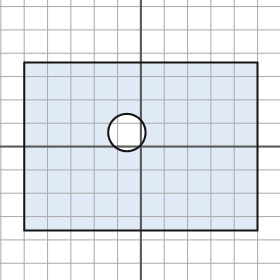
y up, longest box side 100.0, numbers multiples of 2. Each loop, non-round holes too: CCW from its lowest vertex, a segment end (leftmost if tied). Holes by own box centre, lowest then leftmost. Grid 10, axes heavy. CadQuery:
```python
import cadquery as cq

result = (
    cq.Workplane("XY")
    .moveTo(-50.0, -36.0)
    .lineTo(50.0, -36.0)
    .lineTo(50.0, 36.0)
    .lineTo(-50.0, 36.0)
    .close()
    .moveTo(-6.0, 6.0)
    .circle(8.0)
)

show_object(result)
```